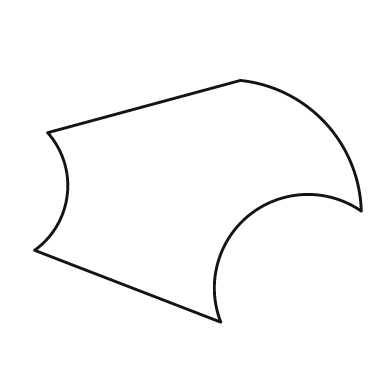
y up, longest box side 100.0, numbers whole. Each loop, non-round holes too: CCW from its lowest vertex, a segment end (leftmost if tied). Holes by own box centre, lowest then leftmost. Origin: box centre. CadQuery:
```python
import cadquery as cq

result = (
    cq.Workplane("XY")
    .moveTo(7.0, -37.0)
    .threePointArc((16.0, -4.0), (50.0, -3.0))
    .threePointArc((39.0, 24.0), (13.0, 37.0))
    .lineTo(-46.0, 21.0)
    .threePointArc((-40.0, 2.0), (-50.0, -15.0))
    .close()
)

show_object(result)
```